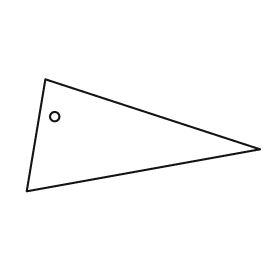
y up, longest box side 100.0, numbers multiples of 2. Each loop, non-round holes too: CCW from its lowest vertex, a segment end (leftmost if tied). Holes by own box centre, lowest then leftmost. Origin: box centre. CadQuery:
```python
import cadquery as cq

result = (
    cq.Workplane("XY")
    .moveTo(-50.0, -24.0)
    .lineTo(50.0, -6.0)
    .lineTo(-42.0, 24.0)
    .close()
    .moveTo(-38.0, 8.0)
    .circle(2.0)
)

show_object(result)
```